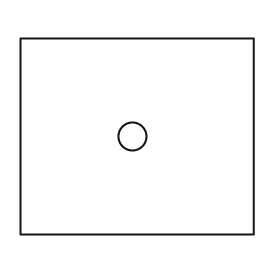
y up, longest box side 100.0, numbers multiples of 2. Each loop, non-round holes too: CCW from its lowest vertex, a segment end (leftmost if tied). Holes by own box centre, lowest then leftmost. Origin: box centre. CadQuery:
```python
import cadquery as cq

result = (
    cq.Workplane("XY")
    .moveTo(-50.0, -42.0)
    .lineTo(50.0, -42.0)
    .lineTo(50.0, 42.0)
    .lineTo(-50.0, 42.0)
    .close()
    .moveTo(-2.0, 0.0)
    .circle(6.0)
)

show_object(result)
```